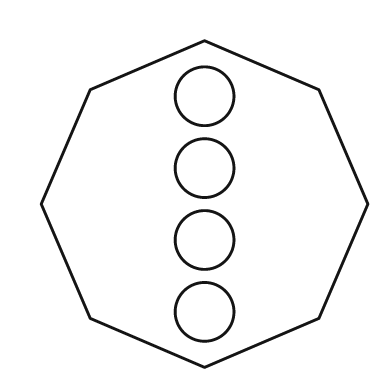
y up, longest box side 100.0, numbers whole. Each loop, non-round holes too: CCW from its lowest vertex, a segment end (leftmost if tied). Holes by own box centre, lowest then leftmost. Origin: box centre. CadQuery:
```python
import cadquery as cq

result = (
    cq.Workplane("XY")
    .moveTo(0.0, -50.0)
    .lineTo(35.0, -35.0)
    .lineTo(50.0, 0.0)
    .lineTo(35.0, 35.0)
    .lineTo(0.0, 50.0)
    .lineTo(-35.0, 35.0)
    .lineTo(-50.0, 0.0)
    .lineTo(-35.0, -35.0)
    .close()
    .moveTo(0.0, -33.0)
    .circle(9.0)
    .moveTo(0.0, -11.0)
    .circle(9.0)
    .moveTo(0.0, 11.0)
    .circle(9.0)
    .moveTo(0.0, 33.0)
    .circle(9.0)
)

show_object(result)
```